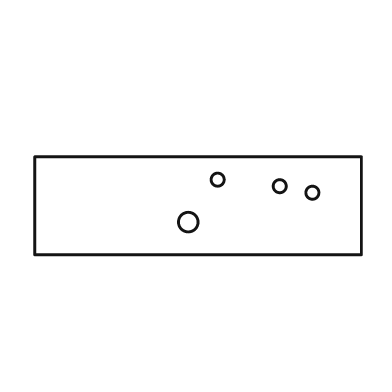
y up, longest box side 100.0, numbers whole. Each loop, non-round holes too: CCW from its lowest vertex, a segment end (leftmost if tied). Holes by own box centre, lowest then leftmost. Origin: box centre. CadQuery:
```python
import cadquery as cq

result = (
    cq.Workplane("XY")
    .moveTo(-50.0, -15.0)
    .lineTo(50.0, -15.0)
    .lineTo(50.0, 15.0)
    .lineTo(-50.0, 15.0)
    .close()
    .moveTo(-3.0, -5.0)
    .circle(3.0)
    .moveTo(35.0, 4.0)
    .circle(2.0)
    .moveTo(25.0, 6.0)
    .circle(2.0)
    .moveTo(6.0, 8.0)
    .circle(2.0)
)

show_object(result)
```